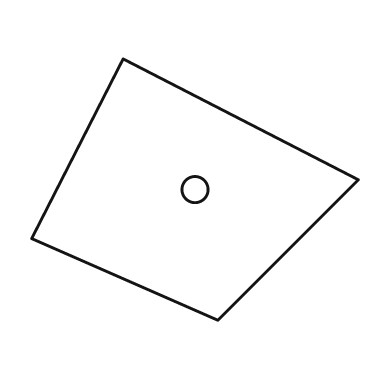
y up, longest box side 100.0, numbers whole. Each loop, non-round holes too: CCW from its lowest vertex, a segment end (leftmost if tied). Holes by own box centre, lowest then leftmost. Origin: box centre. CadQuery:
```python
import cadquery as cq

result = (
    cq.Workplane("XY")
    .moveTo(7.0, -40.0)
    .lineTo(50.0, 3.0)
    .lineTo(-22.0, 40.0)
    .lineTo(-50.0, -15.0)
    .close()
    .moveTo(0.0, 0.0)
    .circle(4.0)
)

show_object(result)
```